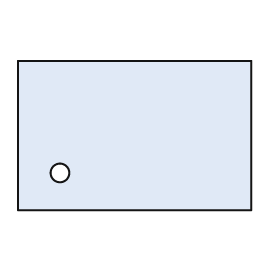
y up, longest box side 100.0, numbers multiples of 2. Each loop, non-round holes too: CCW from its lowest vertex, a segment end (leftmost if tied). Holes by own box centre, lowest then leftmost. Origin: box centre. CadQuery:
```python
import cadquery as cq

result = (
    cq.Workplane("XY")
    .moveTo(-50.0, -32.0)
    .lineTo(50.0, -32.0)
    .lineTo(50.0, 32.0)
    .lineTo(-50.0, 32.0)
    .close()
    .moveTo(-32.0, -16.0)
    .circle(4.0)
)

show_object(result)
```